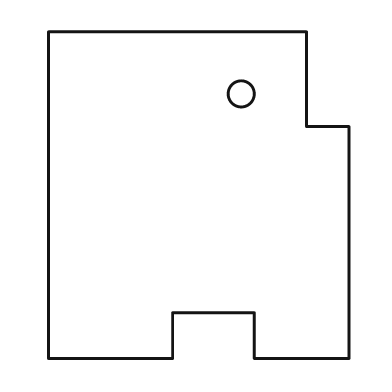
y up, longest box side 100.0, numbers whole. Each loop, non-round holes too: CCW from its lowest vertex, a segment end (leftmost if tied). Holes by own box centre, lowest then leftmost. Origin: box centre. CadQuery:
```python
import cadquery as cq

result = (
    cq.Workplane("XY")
    .moveTo(-46.0, -50.0)
    .lineTo(-8.0, -50.0)
    .lineTo(-8.0, -36.0)
    .lineTo(17.0, -36.0)
    .lineTo(17.0, -50.0)
    .lineTo(46.0, -50.0)
    .lineTo(46.0, 21.0)
    .lineTo(33.0, 21.0)
    .lineTo(33.0, 50.0)
    .lineTo(-46.0, 50.0)
    .close()
    .moveTo(13.0, 31.0)
    .circle(4.0)
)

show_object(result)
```